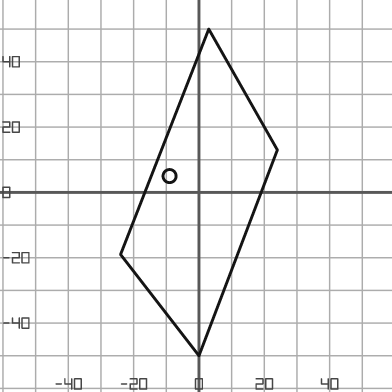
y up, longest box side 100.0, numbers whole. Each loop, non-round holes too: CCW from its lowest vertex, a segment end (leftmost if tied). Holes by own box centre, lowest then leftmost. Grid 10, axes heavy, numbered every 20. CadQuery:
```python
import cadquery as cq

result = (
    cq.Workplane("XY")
    .moveTo(0.0, -50.0)
    .lineTo(24.0, 13.0)
    .lineTo(3.0, 50.0)
    .lineTo(-24.0, -19.0)
    .close()
    .moveTo(-9.0, 5.0)
    .circle(2.0)
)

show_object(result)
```